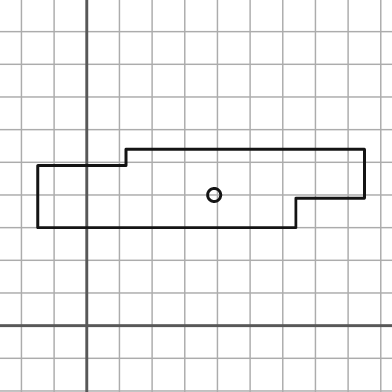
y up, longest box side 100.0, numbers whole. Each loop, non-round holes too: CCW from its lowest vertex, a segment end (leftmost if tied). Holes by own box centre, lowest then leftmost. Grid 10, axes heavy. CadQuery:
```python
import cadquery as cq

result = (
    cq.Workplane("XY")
    .moveTo(-15.0, 30.0)
    .lineTo(64.0, 30.0)
    .lineTo(64.0, 39.0)
    .lineTo(85.0, 39.0)
    .lineTo(85.0, 54.0)
    .lineTo(12.0, 54.0)
    .lineTo(12.0, 49.0)
    .lineTo(-15.0, 49.0)
    .close()
    .moveTo(39.0, 40.0)
    .circle(2.0)
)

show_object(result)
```